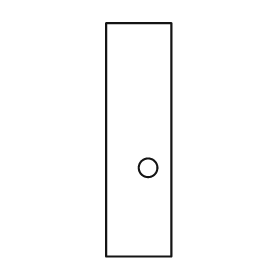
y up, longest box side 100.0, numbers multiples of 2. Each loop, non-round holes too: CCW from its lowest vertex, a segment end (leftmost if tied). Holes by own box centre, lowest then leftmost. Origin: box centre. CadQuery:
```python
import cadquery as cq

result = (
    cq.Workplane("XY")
    .moveTo(-14.0, -50.0)
    .lineTo(14.0, -50.0)
    .lineTo(14.0, 50.0)
    .lineTo(-14.0, 50.0)
    .close()
    .moveTo(4.0, -12.0)
    .circle(4.0)
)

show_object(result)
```